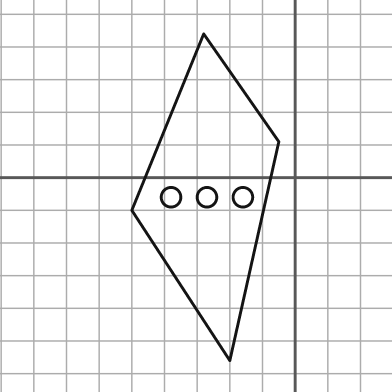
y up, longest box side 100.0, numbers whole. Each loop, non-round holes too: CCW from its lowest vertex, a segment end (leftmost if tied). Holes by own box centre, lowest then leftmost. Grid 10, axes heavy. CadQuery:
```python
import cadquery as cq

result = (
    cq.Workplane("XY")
    .moveTo(-20.0, -56.0)
    .lineTo(-5.0, 11.0)
    .lineTo(-28.0, 44.0)
    .lineTo(-50.0, -10.0)
    .close()
    .moveTo(-38.0, -6.0)
    .circle(3.0)
    .moveTo(-27.0, -6.0)
    .circle(3.0)
    .moveTo(-16.0, -6.0)
    .circle(3.0)
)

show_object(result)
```